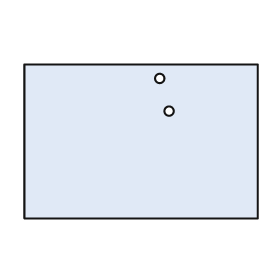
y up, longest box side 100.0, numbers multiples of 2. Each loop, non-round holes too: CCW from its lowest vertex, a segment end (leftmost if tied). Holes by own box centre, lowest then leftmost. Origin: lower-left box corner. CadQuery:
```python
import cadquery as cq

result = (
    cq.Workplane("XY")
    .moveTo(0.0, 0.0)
    .lineTo(100.0, 0.0)
    .lineTo(100.0, 66.0)
    .lineTo(0.0, 66.0)
    .close()
    .moveTo(62.0, 46.0)
    .circle(2.0)
    .moveTo(58.0, 60.0)
    .circle(2.0)
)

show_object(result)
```